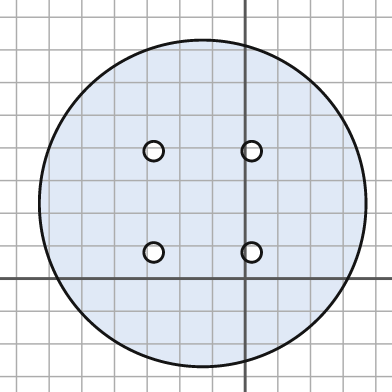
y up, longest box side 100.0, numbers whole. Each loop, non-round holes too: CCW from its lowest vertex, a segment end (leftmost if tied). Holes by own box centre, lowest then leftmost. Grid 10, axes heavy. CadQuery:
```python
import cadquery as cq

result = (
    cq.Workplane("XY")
    .moveTo(-13.0, 23.0)
    .circle(50.0)
    .moveTo(-28.0, 8.0)
    .circle(3.0)
    .moveTo(2.0, 8.0)
    .circle(3.0)
    .moveTo(-28.0, 39.0)
    .circle(3.0)
    .moveTo(2.0, 39.0)
    .circle(3.0)
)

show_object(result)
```